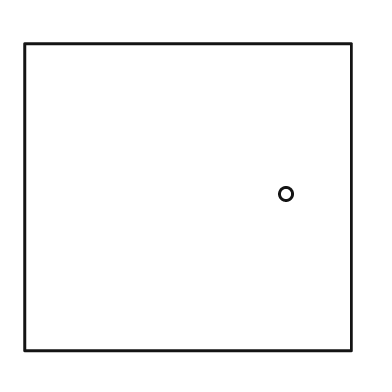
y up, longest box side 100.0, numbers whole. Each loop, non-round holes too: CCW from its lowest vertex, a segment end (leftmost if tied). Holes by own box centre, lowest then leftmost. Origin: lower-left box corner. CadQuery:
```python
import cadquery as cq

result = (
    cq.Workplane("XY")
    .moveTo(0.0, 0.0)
    .lineTo(100.0, 0.0)
    .lineTo(100.0, 94.0)
    .lineTo(0.0, 94.0)
    .close()
    .moveTo(80.0, 48.0)
    .circle(2.0)
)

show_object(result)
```